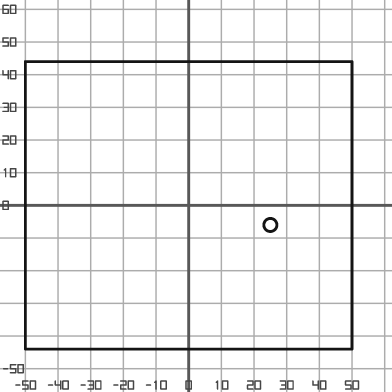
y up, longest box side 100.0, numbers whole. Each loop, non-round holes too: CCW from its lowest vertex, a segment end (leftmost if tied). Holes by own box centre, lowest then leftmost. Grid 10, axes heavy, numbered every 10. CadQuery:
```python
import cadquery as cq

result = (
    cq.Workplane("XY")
    .moveTo(-50.0, -44.0)
    .lineTo(50.0, -44.0)
    .lineTo(50.0, 44.0)
    .lineTo(-50.0, 44.0)
    .close()
    .moveTo(25.0, -6.0)
    .circle(2.0)
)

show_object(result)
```